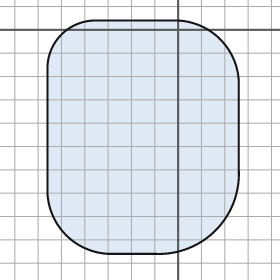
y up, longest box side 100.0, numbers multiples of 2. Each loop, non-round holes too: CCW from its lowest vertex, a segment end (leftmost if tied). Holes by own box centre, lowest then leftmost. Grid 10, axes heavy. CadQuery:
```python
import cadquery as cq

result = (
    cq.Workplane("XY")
    .moveTo(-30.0, -96.0)
    .lineTo(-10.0, -96.0)
    .threePointArc((16.0, -86.0), (26.0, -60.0))
    .lineTo(26.0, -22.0)
    .threePointArc((18.0, -4.0), (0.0, 4.0))
    .lineTo(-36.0, 4.0)
    .threePointArc((-50.0, -2.0), (-56.0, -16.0))
    .lineTo(-56.0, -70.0)
    .threePointArc((-48.0, -88.0), (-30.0, -96.0))
    .close()
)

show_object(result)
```